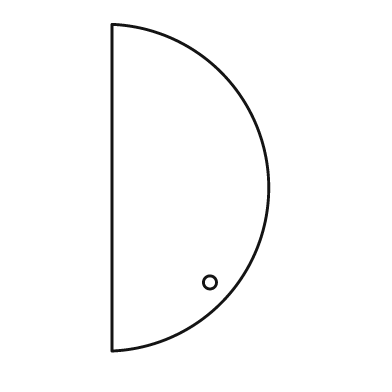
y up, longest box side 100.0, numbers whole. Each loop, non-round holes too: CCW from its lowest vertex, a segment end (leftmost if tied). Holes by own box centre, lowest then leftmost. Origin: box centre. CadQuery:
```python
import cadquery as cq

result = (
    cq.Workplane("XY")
    .moveTo(-24.0, -50.0)
    .threePointArc((24.0, 0.0), (-24.0, 50.0))
    .close()
    .moveTo(6.0, -29.0)
    .circle(2.0)
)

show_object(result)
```